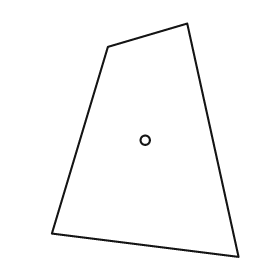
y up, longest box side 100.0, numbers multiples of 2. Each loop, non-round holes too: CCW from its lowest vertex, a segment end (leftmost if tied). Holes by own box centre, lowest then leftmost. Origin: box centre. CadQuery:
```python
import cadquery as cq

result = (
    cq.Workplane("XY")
    .moveTo(40.0, -50.0)
    .lineTo(18.0, 50.0)
    .lineTo(-16.0, 40.0)
    .lineTo(-40.0, -40.0)
    .close()
    .moveTo(0.0, 0.0)
    .circle(2.0)
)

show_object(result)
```